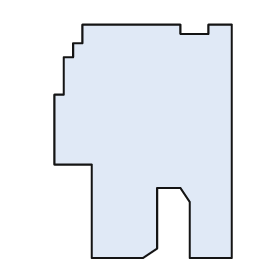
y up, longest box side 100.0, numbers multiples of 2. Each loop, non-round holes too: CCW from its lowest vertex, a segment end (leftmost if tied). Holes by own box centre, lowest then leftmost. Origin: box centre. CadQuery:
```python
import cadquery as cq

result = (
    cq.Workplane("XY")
    .moveTo(-22.0, -50.0)
    .lineTo(0.0, -50.0)
    .lineTo(6.0, -46.0)
    .lineTo(6.0, -20.0)
    .lineTo(16.0, -20.0)
    .lineTo(20.0, -26.0)
    .lineTo(20.0, -50.0)
    .lineTo(38.0, -50.0)
    .lineTo(38.0, 50.0)
    .lineTo(28.0, 50.0)
    .lineTo(28.0, 46.0)
    .lineTo(16.0, 46.0)
    .lineTo(16.0, 50.0)
    .lineTo(-26.0, 50.0)
    .lineTo(-26.0, 42.0)
    .lineTo(-30.0, 42.0)
    .lineTo(-30.0, 36.0)
    .lineTo(-34.0, 36.0)
    .lineTo(-34.0, 20.0)
    .lineTo(-38.0, 20.0)
    .lineTo(-38.0, -10.0)
    .lineTo(-22.0, -10.0)
    .close()
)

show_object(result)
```